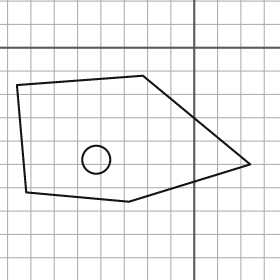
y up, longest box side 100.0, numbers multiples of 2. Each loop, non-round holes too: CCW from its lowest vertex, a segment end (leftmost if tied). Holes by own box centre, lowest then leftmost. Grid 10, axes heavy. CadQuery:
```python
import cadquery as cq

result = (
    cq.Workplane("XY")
    .moveTo(-28.0, -66.0)
    .lineTo(24.0, -50.0)
    .lineTo(-22.0, -12.0)
    .lineTo(-76.0, -16.0)
    .lineTo(-72.0, -62.0)
    .close()
    .moveTo(-42.0, -48.0)
    .circle(6.0)
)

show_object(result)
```